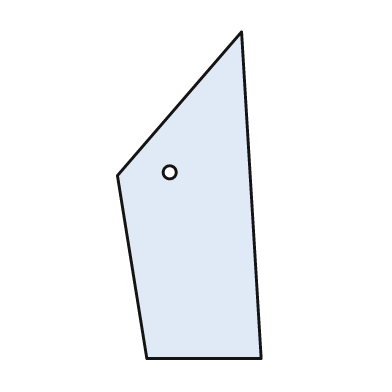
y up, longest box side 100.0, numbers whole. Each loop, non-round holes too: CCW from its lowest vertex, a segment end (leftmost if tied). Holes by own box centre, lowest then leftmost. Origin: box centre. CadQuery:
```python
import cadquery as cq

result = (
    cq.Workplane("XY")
    .moveTo(-13.0, -50.0)
    .lineTo(22.0, -50.0)
    .lineTo(16.0, 50.0)
    .lineTo(-22.0, 6.0)
    .close()
    .moveTo(-6.0, 7.0)
    .circle(2.0)
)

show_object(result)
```